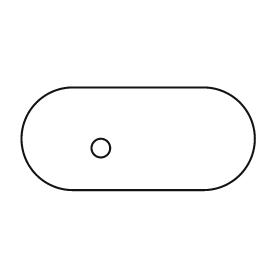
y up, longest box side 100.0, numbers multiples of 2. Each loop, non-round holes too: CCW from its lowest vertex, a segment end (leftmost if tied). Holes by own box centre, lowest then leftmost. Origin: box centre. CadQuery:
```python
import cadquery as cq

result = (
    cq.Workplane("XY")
    .moveTo(-28.0, -22.0)
    .lineTo(28.0, -22.0)
    .threePointArc((50.0, 0.0), (28.0, 22.0))
    .lineTo(-28.0, 22.0)
    .threePointArc((-50.0, 0.0), (-28.0, -22.0))
    .close()
    .moveTo(-16.0, -4.0)
    .circle(4.0)
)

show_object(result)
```